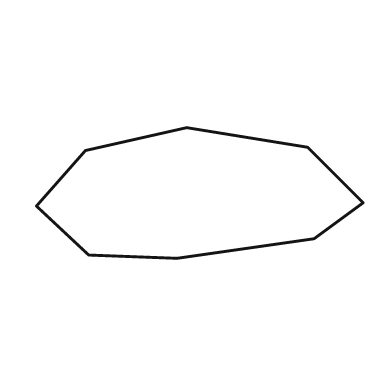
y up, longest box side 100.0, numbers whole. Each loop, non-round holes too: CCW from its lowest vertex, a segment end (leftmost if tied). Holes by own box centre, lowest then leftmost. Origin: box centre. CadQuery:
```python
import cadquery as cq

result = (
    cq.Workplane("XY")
    .moveTo(-7.0, -20.0)
    .lineTo(35.0, -14.0)
    .lineTo(50.0, -3.0)
    .lineTo(33.0, 14.0)
    .lineTo(-4.0, 20.0)
    .lineTo(-35.0, 13.0)
    .lineTo(-50.0, -4.0)
    .lineTo(-34.0, -19.0)
    .close()
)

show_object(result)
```